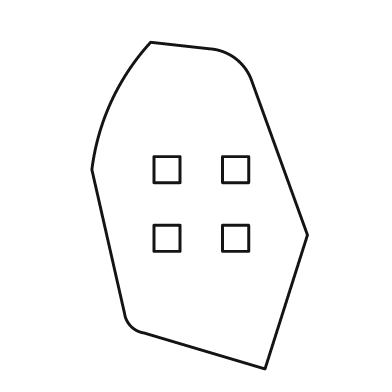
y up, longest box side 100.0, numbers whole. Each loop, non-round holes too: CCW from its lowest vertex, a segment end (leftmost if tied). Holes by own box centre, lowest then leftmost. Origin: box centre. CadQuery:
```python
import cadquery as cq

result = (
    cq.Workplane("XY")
    .moveTo(20.0, -50.0)
    .lineTo(33.0, -9.0)
    .lineTo(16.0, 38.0)
    .threePointArc((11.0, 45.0), (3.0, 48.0))
    .lineTo(-15.0, 50.0)
    .threePointArc((-27.0, 32.0), (-33.0, 11.0))
    .lineTo(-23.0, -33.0)
    .threePointArc((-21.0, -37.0), (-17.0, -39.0))
    .close()
    .moveTo(-14.0, -14.0)
    .lineTo(-6.0, -14.0)
    .lineTo(-6.0, -6.0)
    .lineTo(-14.0, -6.0)
    .close()
    .moveTo(7.0, -14.0)
    .lineTo(15.0, -14.0)
    .lineTo(15.0, -6.0)
    .lineTo(7.0, -6.0)
    .close()
    .moveTo(-14.0, 7.0)
    .lineTo(-6.0, 7.0)
    .lineTo(-6.0, 15.0)
    .lineTo(-14.0, 15.0)
    .close()
    .moveTo(7.0, 7.0)
    .lineTo(15.0, 7.0)
    .lineTo(15.0, 15.0)
    .lineTo(7.0, 15.0)
    .close()
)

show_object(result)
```